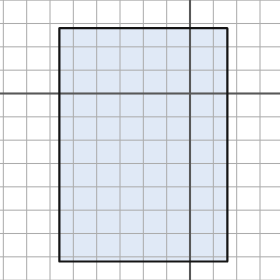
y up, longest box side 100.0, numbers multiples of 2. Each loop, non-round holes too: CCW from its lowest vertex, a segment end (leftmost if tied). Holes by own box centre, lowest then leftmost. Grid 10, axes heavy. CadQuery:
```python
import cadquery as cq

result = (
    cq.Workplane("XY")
    .moveTo(-56.0, -72.0)
    .lineTo(16.0, -72.0)
    .lineTo(16.0, 28.0)
    .lineTo(-56.0, 28.0)
    .close()
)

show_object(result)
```